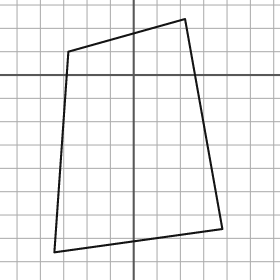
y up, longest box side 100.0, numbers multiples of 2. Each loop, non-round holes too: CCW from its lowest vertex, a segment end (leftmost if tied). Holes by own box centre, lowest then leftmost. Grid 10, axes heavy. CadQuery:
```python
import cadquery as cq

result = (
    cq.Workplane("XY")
    .moveTo(-34.0, -76.0)
    .lineTo(38.0, -66.0)
    .lineTo(22.0, 24.0)
    .lineTo(-28.0, 10.0)
    .close()
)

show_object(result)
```